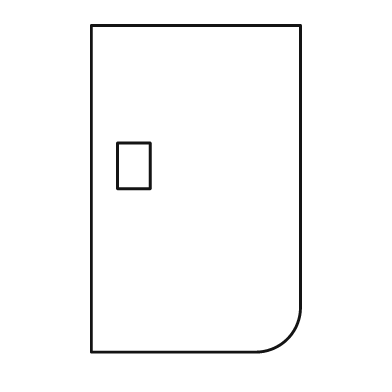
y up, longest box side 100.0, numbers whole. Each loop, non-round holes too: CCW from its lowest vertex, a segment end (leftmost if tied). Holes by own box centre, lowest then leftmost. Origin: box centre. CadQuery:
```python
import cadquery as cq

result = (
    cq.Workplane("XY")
    .moveTo(-32.0, -50.0)
    .lineTo(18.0, -50.0)
    .threePointArc((28.0, -46.0), (32.0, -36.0))
    .lineTo(32.0, 50.0)
    .lineTo(-32.0, 50.0)
    .close()
    .moveTo(-24.0, 0.0)
    .lineTo(-14.0, 0.0)
    .lineTo(-14.0, 14.0)
    .lineTo(-24.0, 14.0)
    .close()
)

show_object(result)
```